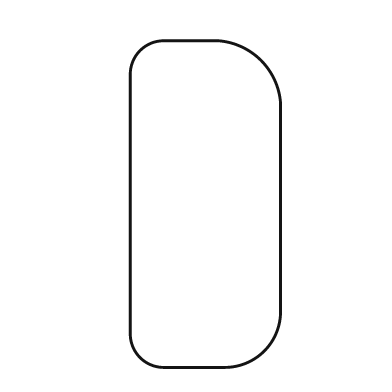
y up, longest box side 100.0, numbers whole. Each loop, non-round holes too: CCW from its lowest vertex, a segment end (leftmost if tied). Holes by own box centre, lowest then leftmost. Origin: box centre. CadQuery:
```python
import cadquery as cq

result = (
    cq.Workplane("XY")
    .moveTo(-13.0, -50.0)
    .lineTo(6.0, -50.0)
    .threePointArc((18.0, -45.0), (23.0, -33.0))
    .lineTo(23.0, 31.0)
    .threePointArc((17.0, 44.0), (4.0, 50.0))
    .lineTo(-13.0, 50.0)
    .threePointArc((-20.0, 47.0), (-23.0, 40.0))
    .lineTo(-23.0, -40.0)
    .threePointArc((-20.0, -47.0), (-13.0, -50.0))
    .close()
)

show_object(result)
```